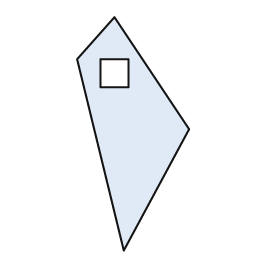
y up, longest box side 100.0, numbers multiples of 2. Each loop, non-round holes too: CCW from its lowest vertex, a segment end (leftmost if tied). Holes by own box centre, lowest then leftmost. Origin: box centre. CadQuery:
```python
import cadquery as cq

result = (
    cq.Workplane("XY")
    .moveTo(-4.0, -50.0)
    .lineTo(24.0, 2.0)
    .lineTo(-8.0, 50.0)
    .lineTo(-24.0, 32.0)
    .close()
    .moveTo(-14.0, 20.0)
    .lineTo(-2.0, 20.0)
    .lineTo(-2.0, 32.0)
    .lineTo(-14.0, 32.0)
    .close()
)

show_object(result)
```